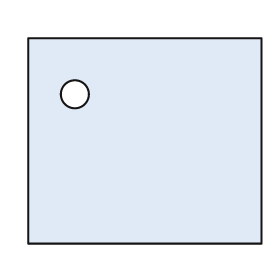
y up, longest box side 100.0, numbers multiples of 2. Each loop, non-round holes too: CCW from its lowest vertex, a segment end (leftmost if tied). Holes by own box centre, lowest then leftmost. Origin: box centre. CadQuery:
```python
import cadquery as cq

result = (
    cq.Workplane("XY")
    .moveTo(-50.0, -44.0)
    .lineTo(50.0, -44.0)
    .lineTo(50.0, 44.0)
    .lineTo(-50.0, 44.0)
    .close()
    .moveTo(-30.0, 20.0)
    .circle(6.0)
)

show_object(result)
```